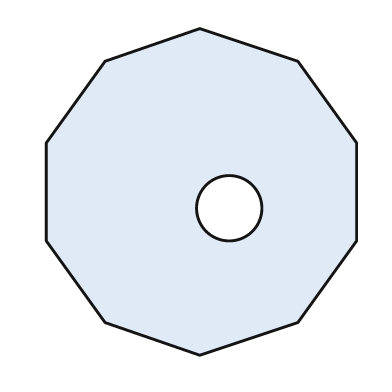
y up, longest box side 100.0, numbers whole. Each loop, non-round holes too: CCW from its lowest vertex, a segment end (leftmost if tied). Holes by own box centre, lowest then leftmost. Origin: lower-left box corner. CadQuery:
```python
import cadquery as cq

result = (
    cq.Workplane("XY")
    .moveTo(47.0, 0.0)
    .lineTo(77.0, 10.0)
    .lineTo(95.0, 35.0)
    .lineTo(95.0, 65.0)
    .lineTo(77.0, 90.0)
    .lineTo(47.0, 100.0)
    .lineTo(18.0, 90.0)
    .lineTo(0.0, 65.0)
    .lineTo(0.0, 35.0)
    .lineTo(18.0, 10.0)
    .close()
    .moveTo(56.0, 45.0)
    .circle(10.0)
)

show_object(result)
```